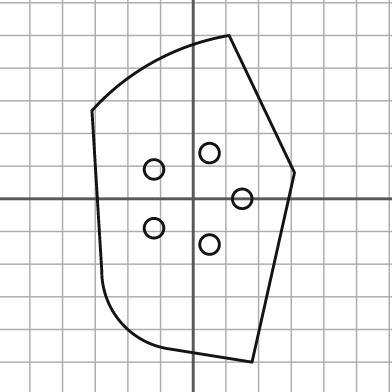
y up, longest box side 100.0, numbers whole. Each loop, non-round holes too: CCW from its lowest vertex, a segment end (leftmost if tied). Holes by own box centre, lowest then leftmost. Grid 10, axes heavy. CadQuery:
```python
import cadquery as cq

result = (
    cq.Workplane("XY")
    .moveTo(18.0, -50.0)
    .lineTo(31.0, 8.0)
    .lineTo(11.0, 50.0)
    .threePointArc((-12.0, 42.0), (-31.0, 27.0))
    .lineTo(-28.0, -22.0)
    .threePointArc((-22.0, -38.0), (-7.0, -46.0))
    .close()
    .moveTo(5.0, -14.0)
    .circle(3.0)
    .moveTo(-12.0, -9.0)
    .circle(3.0)
    .moveTo(15.0, 0.0)
    .circle(3.0)
    .moveTo(-12.0, 9.0)
    .circle(3.0)
    .moveTo(5.0, 14.0)
    .circle(3.0)
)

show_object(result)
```